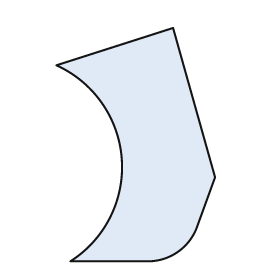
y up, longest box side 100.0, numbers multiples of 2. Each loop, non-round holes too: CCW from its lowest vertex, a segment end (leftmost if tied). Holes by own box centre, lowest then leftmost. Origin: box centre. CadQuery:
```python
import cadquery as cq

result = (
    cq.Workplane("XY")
    .moveTo(-28.0, -50.0)
    .lineTo(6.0, -50.0)
    .threePointArc((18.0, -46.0), (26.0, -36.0))
    .lineTo(34.0, -14.0)
    .lineTo(16.0, 50.0)
    .lineTo(-34.0, 34.0)
    .threePointArc((-6.0, -6.0), (-28.0, -50.0))
    .close()
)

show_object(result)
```